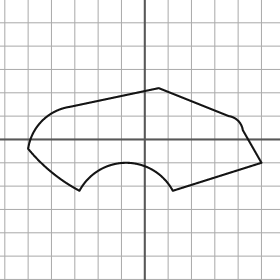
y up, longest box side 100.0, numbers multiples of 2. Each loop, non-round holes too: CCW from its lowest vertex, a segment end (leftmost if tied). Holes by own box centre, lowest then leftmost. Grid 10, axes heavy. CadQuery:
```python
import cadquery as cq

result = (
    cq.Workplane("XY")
    .moveTo(-28.0, -22.0)
    .threePointArc((-8.0, -10.0), (12.0, -22.0))
    .lineTo(50.0, -10.0)
    .lineTo(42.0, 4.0)
    .threePointArc((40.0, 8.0), (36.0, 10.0))
    .lineTo(6.0, 22.0)
    .lineTo(-32.0, 14.0)
    .threePointArc((-44.0, 8.0), (-50.0, -4.0))
    .threePointArc((-40.0, -14.0), (-28.0, -22.0))
    .close()
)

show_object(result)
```